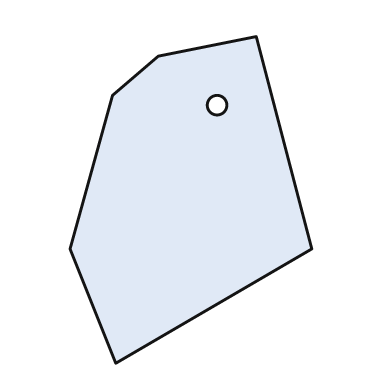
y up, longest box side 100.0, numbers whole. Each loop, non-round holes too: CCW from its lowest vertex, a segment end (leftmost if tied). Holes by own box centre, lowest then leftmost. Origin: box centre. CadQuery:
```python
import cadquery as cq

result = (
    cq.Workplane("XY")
    .moveTo(-23.0, -50.0)
    .lineTo(37.0, -15.0)
    .lineTo(20.0, 50.0)
    .lineTo(-10.0, 44.0)
    .lineTo(-24.0, 32.0)
    .lineTo(-37.0, -15.0)
    .close()
    .moveTo(8.0, 29.0)
    .circle(3.0)
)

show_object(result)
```